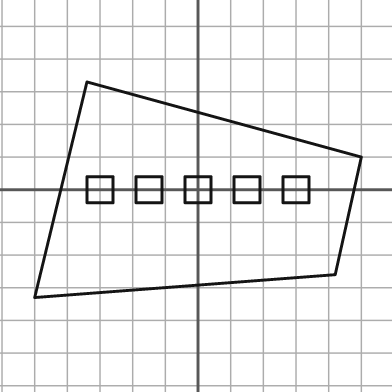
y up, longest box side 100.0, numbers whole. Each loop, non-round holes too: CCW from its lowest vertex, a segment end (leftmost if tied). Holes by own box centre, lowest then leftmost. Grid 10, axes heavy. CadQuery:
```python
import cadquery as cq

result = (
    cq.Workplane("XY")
    .moveTo(-50.0, -33.0)
    .lineTo(42.0, -26.0)
    .lineTo(50.0, 10.0)
    .lineTo(-34.0, 33.0)
    .close()
    .moveTo(-34.0, -4.0)
    .lineTo(-26.0, -4.0)
    .lineTo(-26.0, 4.0)
    .lineTo(-34.0, 4.0)
    .close()
    .moveTo(-19.0, -4.0)
    .lineTo(-11.0, -4.0)
    .lineTo(-11.0, 4.0)
    .lineTo(-19.0, 4.0)
    .close()
    .moveTo(-4.0, -4.0)
    .lineTo(4.0, -4.0)
    .lineTo(4.0, 4.0)
    .lineTo(-4.0, 4.0)
    .close()
    .moveTo(11.0, -4.0)
    .lineTo(19.0, -4.0)
    .lineTo(19.0, 4.0)
    .lineTo(11.0, 4.0)
    .close()
    .moveTo(26.0, -4.0)
    .lineTo(34.0, -4.0)
    .lineTo(34.0, 4.0)
    .lineTo(26.0, 4.0)
    .close()
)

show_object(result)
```